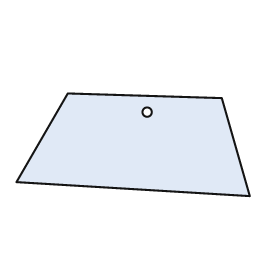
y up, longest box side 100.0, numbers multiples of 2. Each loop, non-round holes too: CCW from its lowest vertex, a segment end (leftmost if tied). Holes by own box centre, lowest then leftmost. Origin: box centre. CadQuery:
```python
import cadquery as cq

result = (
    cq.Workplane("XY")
    .moveTo(50.0, -22.0)
    .lineTo(38.0, 20.0)
    .lineTo(-28.0, 22.0)
    .lineTo(-50.0, -16.0)
    .close()
    .moveTo(6.0, 14.0)
    .circle(2.0)
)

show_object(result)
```